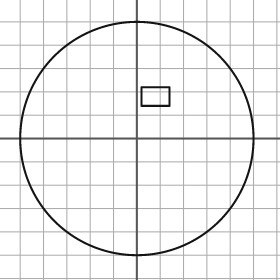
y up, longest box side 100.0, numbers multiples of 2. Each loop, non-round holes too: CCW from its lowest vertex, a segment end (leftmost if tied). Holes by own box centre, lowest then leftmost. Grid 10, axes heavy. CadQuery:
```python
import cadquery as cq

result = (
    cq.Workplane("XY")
    .moveTo(0.0, 0.0)
    .circle(50.0)
    .moveTo(2.0, 14.0)
    .lineTo(14.0, 14.0)
    .lineTo(14.0, 22.0)
    .lineTo(2.0, 22.0)
    .close()
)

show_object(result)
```